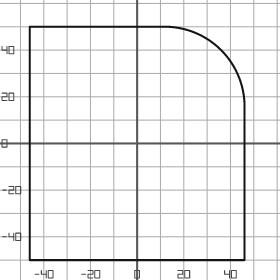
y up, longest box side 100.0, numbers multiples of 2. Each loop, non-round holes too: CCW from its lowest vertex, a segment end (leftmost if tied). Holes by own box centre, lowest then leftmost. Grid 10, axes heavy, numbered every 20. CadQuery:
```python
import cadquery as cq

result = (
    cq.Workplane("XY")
    .moveTo(-46.0, -50.0)
    .lineTo(46.0, -50.0)
    .lineTo(46.0, 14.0)
    .threePointArc((36.0, 40.0), (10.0, 50.0))
    .lineTo(-46.0, 50.0)
    .close()
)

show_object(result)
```